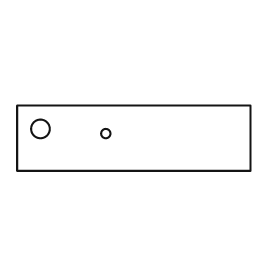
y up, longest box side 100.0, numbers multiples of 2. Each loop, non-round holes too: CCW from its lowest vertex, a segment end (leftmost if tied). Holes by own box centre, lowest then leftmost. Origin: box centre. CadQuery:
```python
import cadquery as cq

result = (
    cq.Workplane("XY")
    .moveTo(-50.0, -14.0)
    .lineTo(50.0, -14.0)
    .lineTo(50.0, 14.0)
    .lineTo(-50.0, 14.0)
    .close()
    .moveTo(-12.0, 2.0)
    .circle(2.0)
    .moveTo(-40.0, 4.0)
    .circle(4.0)
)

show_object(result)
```